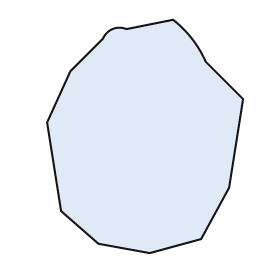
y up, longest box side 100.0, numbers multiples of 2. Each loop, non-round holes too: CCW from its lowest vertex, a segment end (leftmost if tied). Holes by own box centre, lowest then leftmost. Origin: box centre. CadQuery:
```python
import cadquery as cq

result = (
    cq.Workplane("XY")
    .moveTo(2.0, -50.0)
    .lineTo(24.0, -44.0)
    .lineTo(36.0, -22.0)
    .lineTo(42.0, 16.0)
    .lineTo(26.0, 32.0)
    .threePointArc((20.0, 42.0), (12.0, 50.0))
    .lineTo(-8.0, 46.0)
    .threePointArc((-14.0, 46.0), (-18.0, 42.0))
    .lineTo(-32.0, 28.0)
    .lineTo(-42.0, 6.0)
    .lineTo(-36.0, -32.0)
    .lineTo(-20.0, -46.0)
    .close()
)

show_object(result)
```